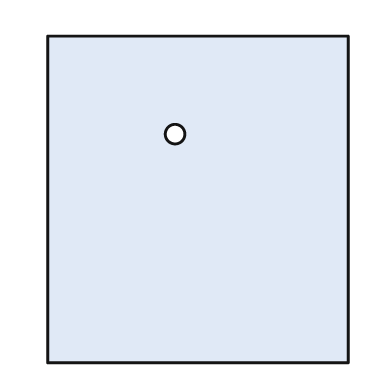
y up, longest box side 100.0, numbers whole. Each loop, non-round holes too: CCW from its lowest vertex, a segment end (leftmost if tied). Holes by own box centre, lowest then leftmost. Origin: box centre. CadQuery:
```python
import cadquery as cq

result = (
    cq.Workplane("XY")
    .moveTo(-46.0, -50.0)
    .lineTo(46.0, -50.0)
    .lineTo(46.0, 50.0)
    .lineTo(-46.0, 50.0)
    .close()
    .moveTo(-7.0, 20.0)
    .circle(3.0)
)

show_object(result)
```